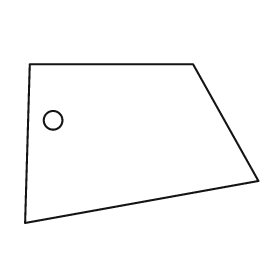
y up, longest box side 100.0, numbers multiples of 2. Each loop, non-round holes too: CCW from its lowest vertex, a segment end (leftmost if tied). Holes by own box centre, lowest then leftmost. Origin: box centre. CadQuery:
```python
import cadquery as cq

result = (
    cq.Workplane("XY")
    .moveTo(-50.0, -34.0)
    .lineTo(50.0, -16.0)
    .lineTo(22.0, 34.0)
    .lineTo(-48.0, 34.0)
    .close()
    .moveTo(-38.0, 10.0)
    .circle(4.0)
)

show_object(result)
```